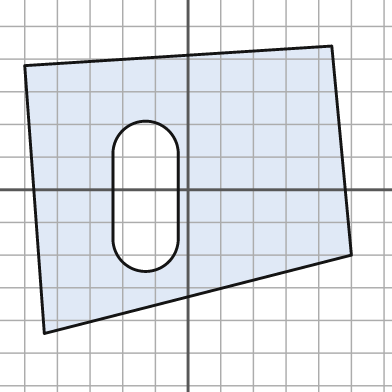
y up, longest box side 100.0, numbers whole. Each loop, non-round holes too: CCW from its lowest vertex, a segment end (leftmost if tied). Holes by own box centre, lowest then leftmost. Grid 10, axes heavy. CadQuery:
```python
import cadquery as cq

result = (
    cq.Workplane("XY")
    .moveTo(-44.0, -44.0)
    .lineTo(50.0, -20.0)
    .lineTo(44.0, 44.0)
    .lineTo(-50.0, 38.0)
    .close()
    .moveTo(-23.0, -15.0)
    .threePointArc((-13.0, -25.0), (-3.0, -15.0))
    .lineTo(-3.0, 11.0)
    .threePointArc((-13.0, 21.0), (-23.0, 11.0))
    .close()
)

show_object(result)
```